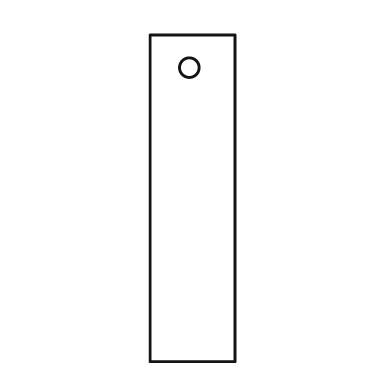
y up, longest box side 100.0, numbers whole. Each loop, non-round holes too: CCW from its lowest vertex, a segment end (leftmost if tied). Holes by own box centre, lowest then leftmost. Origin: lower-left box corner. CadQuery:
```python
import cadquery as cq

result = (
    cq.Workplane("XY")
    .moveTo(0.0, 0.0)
    .lineTo(26.0, 0.0)
    .lineTo(26.0, 100.0)
    .lineTo(0.0, 100.0)
    .close()
    .moveTo(12.0, 90.0)
    .circle(3.0)
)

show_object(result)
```